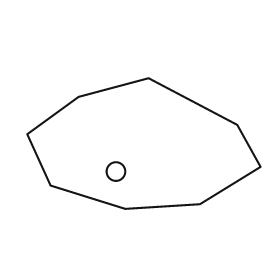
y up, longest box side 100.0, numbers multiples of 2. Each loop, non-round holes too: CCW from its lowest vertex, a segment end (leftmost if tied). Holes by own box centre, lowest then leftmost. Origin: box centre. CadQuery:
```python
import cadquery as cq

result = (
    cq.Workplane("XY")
    .moveTo(-8.0, -28.0)
    .lineTo(24.0, -26.0)
    .lineTo(50.0, -10.0)
    .lineTo(40.0, 8.0)
    .lineTo(2.0, 28.0)
    .lineTo(-28.0, 20.0)
    .lineTo(-50.0, 4.0)
    .lineTo(-40.0, -18.0)
    .close()
    .moveTo(-12.0, -12.0)
    .circle(4.0)
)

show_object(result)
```